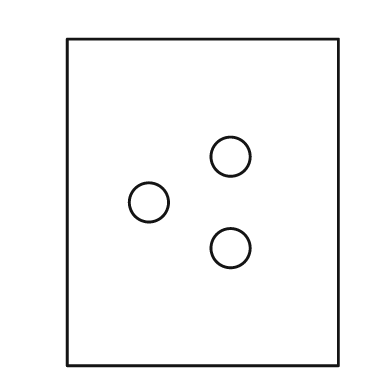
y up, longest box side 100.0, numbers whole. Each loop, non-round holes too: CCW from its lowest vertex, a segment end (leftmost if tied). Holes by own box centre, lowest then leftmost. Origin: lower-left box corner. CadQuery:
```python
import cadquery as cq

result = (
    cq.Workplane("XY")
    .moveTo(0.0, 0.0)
    .lineTo(83.0, 0.0)
    .lineTo(83.0, 100.0)
    .lineTo(0.0, 100.0)
    .close()
    .moveTo(50.0, 36.0)
    .circle(6.0)
    .moveTo(25.0, 50.0)
    .circle(6.0)
    .moveTo(50.0, 64.0)
    .circle(6.0)
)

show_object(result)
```